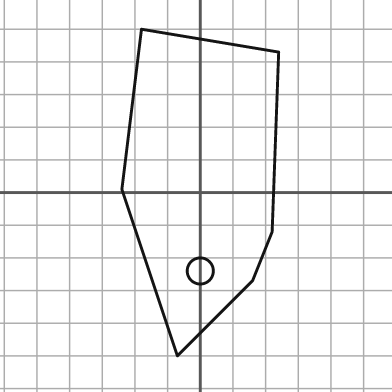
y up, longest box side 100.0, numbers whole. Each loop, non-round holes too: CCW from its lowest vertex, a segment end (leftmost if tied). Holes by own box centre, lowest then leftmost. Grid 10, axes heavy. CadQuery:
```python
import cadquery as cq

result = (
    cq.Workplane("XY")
    .moveTo(-7.0, -50.0)
    .lineTo(16.0, -27.0)
    .lineTo(22.0, -12.0)
    .lineTo(24.0, 43.0)
    .lineTo(-18.0, 50.0)
    .lineTo(-24.0, 1.0)
    .close()
    .moveTo(0.0, -24.0)
    .circle(4.0)
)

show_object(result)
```